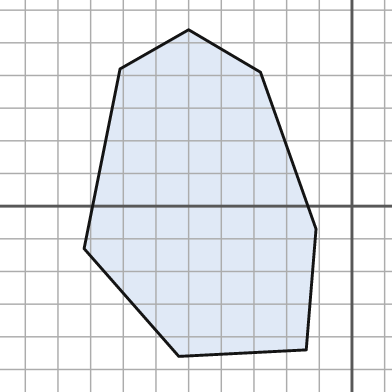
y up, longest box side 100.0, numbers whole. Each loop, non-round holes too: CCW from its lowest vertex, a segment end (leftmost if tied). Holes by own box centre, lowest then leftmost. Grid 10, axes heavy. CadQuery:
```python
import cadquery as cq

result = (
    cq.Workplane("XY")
    .moveTo(-53.0, -46.0)
    .lineTo(-14.0, -44.0)
    .lineTo(-11.0, -7.0)
    .lineTo(-28.0, 41.0)
    .lineTo(-50.0, 54.0)
    .lineTo(-71.0, 42.0)
    .lineTo(-82.0, -13.0)
    .close()
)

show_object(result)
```